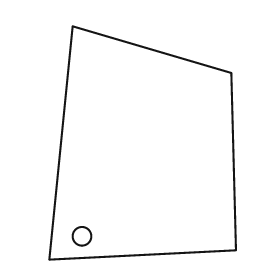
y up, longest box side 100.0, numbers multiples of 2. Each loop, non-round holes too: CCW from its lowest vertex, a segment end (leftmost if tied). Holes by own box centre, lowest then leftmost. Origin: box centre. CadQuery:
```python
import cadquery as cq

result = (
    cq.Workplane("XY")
    .moveTo(-40.0, -50.0)
    .lineTo(40.0, -46.0)
    .lineTo(38.0, 30.0)
    .lineTo(-30.0, 50.0)
    .close()
    .moveTo(-26.0, -40.0)
    .circle(4.0)
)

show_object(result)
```